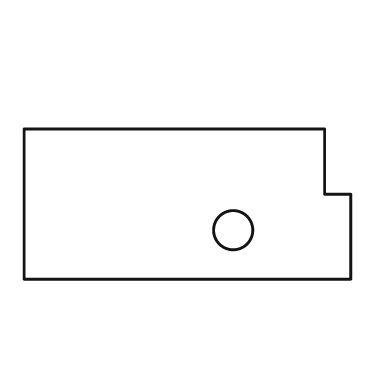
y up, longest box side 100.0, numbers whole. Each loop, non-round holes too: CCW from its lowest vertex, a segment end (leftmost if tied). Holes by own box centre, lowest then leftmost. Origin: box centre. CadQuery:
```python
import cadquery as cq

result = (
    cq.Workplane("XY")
    .moveTo(-50.0, -23.0)
    .lineTo(50.0, -23.0)
    .lineTo(50.0, 3.0)
    .lineTo(42.0, 3.0)
    .lineTo(42.0, 23.0)
    .lineTo(-50.0, 23.0)
    .close()
    .moveTo(14.0, -8.0)
    .circle(6.0)
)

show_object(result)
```